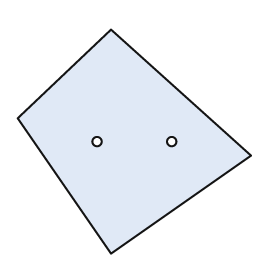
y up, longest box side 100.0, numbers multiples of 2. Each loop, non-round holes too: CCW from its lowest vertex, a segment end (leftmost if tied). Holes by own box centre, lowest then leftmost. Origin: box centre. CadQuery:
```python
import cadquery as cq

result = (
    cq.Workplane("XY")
    .moveTo(-10.0, -48.0)
    .lineTo(50.0, -6.0)
    .lineTo(-10.0, 48.0)
    .lineTo(-50.0, 10.0)
    .close()
    .moveTo(-16.0, 0.0)
    .circle(2.0)
    .moveTo(16.0, 0.0)
    .circle(2.0)
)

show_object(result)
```